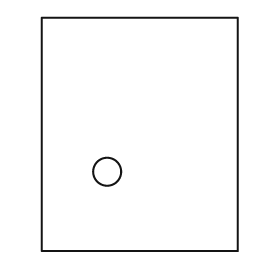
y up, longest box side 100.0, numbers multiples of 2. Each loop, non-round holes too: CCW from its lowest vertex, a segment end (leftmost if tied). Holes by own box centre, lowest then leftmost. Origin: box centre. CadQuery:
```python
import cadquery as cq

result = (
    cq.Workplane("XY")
    .moveTo(-42.0, -50.0)
    .lineTo(42.0, -50.0)
    .lineTo(42.0, 50.0)
    .lineTo(-42.0, 50.0)
    .close()
    .moveTo(-14.0, -16.0)
    .circle(6.0)
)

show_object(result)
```